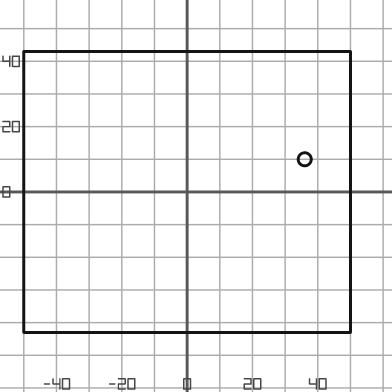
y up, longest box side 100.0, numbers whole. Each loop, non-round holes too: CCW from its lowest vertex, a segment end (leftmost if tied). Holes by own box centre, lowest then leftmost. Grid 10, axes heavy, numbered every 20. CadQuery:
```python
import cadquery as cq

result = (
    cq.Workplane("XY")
    .moveTo(-50.0, -43.0)
    .lineTo(50.0, -43.0)
    .lineTo(50.0, 43.0)
    .lineTo(-50.0, 43.0)
    .close()
    .moveTo(36.0, 10.0)
    .circle(2.0)
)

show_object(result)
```